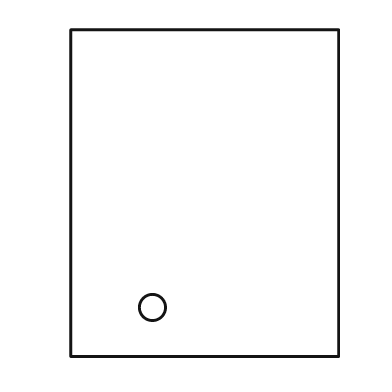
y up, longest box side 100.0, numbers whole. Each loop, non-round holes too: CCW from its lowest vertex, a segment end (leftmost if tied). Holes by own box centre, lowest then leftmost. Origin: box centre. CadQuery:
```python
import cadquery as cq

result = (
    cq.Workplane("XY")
    .moveTo(-41.0, -50.0)
    .lineTo(41.0, -50.0)
    .lineTo(41.0, 50.0)
    .lineTo(-41.0, 50.0)
    .close()
    .moveTo(-16.0, -35.0)
    .circle(4.0)
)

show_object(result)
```